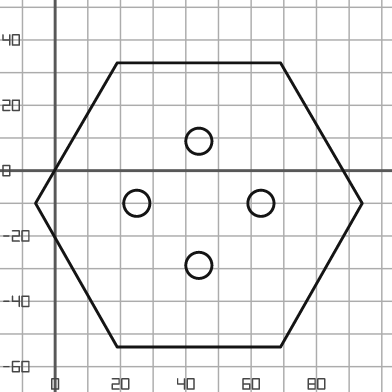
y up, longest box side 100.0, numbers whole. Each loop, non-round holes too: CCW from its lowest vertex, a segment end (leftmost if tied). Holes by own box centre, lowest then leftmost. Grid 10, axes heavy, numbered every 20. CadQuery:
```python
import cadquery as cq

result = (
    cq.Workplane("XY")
    .moveTo(19.0, -54.0)
    .lineTo(69.0, -54.0)
    .lineTo(94.0, -10.0)
    .lineTo(69.0, 33.0)
    .lineTo(19.0, 33.0)
    .lineTo(-6.0, -10.0)
    .close()
    .moveTo(44.0, -29.0)
    .circle(4.0)
    .moveTo(25.0, -10.0)
    .circle(4.0)
    .moveTo(63.0, -10.0)
    .circle(4.0)
    .moveTo(44.0, 9.0)
    .circle(4.0)
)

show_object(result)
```